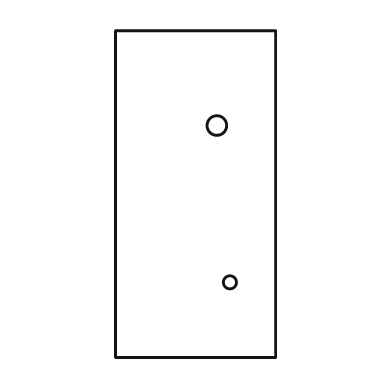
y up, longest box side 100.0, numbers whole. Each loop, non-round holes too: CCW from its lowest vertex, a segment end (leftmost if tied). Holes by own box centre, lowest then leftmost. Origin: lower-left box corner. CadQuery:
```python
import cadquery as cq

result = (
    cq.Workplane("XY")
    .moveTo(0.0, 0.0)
    .lineTo(49.0, 0.0)
    .lineTo(49.0, 100.0)
    .lineTo(0.0, 100.0)
    .close()
    .moveTo(35.0, 23.0)
    .circle(2.0)
    .moveTo(31.0, 71.0)
    .circle(3.0)
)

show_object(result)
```